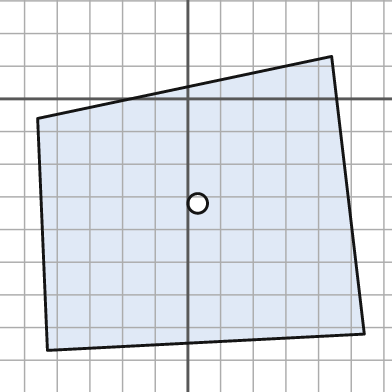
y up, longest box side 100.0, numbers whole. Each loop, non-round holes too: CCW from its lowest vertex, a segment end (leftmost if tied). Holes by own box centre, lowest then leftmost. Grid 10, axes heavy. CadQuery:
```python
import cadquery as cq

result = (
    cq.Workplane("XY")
    .moveTo(-43.0, -77.0)
    .lineTo(54.0, -72.0)
    .lineTo(44.0, 13.0)
    .lineTo(-46.0, -6.0)
    .close()
    .moveTo(3.0, -32.0)
    .circle(3.0)
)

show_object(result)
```